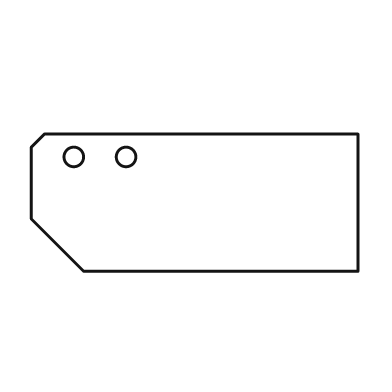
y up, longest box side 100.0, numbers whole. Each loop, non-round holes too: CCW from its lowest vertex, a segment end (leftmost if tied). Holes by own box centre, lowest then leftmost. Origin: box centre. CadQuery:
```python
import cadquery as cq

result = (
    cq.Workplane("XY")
    .moveTo(-34.0, -21.0)
    .lineTo(50.0, -21.0)
    .lineTo(50.0, 21.0)
    .lineTo(-46.0, 21.0)
    .lineTo(-50.0, 17.0)
    .lineTo(-50.0, -5.0)
    .close()
    .moveTo(-37.0, 14.0)
    .circle(3.0)
    .moveTo(-21.0, 14.0)
    .circle(3.0)
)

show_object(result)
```